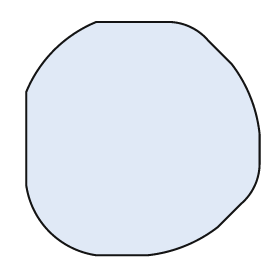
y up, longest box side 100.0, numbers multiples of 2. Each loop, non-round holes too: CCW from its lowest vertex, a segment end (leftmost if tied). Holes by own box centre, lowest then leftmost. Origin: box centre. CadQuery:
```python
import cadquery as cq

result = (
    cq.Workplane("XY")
    .moveTo(-20.0, -50.0)
    .lineTo(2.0, -50.0)
    .threePointArc((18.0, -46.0), (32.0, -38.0))
    .lineTo(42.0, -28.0)
    .threePointArc((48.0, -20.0), (50.0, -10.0))
    .lineTo(50.0, 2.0)
    .threePointArc((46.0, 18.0), (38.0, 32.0))
    .lineTo(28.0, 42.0)
    .threePointArc((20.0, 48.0), (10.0, 50.0))
    .lineTo(-20.0, 50.0)
    .threePointArc((-38.0, 38.0), (-50.0, 20.0))
    .lineTo(-50.0, -20.0)
    .threePointArc((-40.0, -40.0), (-20.0, -50.0))
    .close()
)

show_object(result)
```